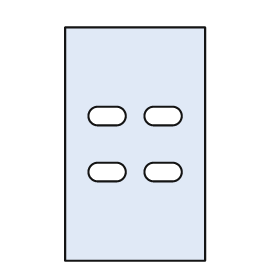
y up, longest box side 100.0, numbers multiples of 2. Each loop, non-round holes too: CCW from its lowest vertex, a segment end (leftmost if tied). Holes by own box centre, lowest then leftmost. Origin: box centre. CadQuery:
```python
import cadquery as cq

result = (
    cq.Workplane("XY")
    .moveTo(-30.0, -50.0)
    .lineTo(30.0, -50.0)
    .lineTo(30.0, 50.0)
    .lineTo(-30.0, 50.0)
    .close()
    .moveTo(-16.0, -16.0)
    .lineTo(-8.0, -16.0)
    .threePointArc((-4.0, -12.0), (-8.0, -8.0))
    .lineTo(-16.0, -8.0)
    .threePointArc((-20.0, -12.0), (-16.0, -16.0))
    .close()
    .moveTo(8.0, -16.0)
    .lineTo(16.0, -16.0)
    .threePointArc((20.0, -12.0), (16.0, -8.0))
    .lineTo(8.0, -8.0)
    .threePointArc((4.0, -12.0), (8.0, -16.0))
    .close()
    .moveTo(-16.0, 8.0)
    .lineTo(-8.0, 8.0)
    .threePointArc((-4.0, 12.0), (-8.0, 16.0))
    .lineTo(-16.0, 16.0)
    .threePointArc((-20.0, 12.0), (-16.0, 8.0))
    .close()
    .moveTo(8.0, 8.0)
    .lineTo(16.0, 8.0)
    .threePointArc((20.0, 12.0), (16.0, 16.0))
    .lineTo(8.0, 16.0)
    .threePointArc((4.0, 12.0), (8.0, 8.0))
    .close()
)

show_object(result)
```